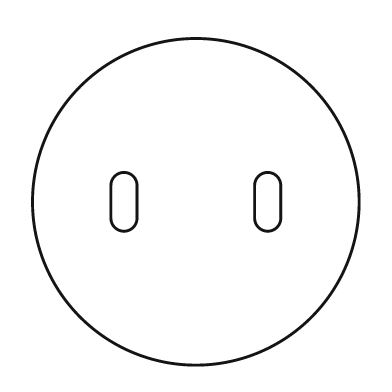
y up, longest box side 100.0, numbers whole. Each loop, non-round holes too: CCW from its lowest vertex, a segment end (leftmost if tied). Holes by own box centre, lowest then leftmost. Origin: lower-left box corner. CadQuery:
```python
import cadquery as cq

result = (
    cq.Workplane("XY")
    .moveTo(50.0, 50.0)
    .circle(50.0)
    .moveTo(24.0, 45.0)
    .threePointArc((28.0, 41.0), (32.0, 45.0))
    .lineTo(32.0, 55.0)
    .threePointArc((28.0, 59.0), (24.0, 55.0))
    .close()
    .moveTo(68.0, 45.0)
    .threePointArc((72.0, 41.0), (76.0, 45.0))
    .lineTo(76.0, 55.0)
    .threePointArc((72.0, 59.0), (68.0, 55.0))
    .close()
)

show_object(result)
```